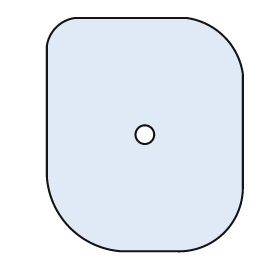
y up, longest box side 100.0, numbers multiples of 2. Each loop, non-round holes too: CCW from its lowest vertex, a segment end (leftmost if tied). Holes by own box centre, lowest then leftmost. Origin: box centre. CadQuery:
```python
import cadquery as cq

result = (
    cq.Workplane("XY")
    .moveTo(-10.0, -50.0)
    .lineTo(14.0, -50.0)
    .threePointArc((34.0, -42.0), (42.0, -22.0))
    .lineTo(42.0, 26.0)
    .threePointArc((34.0, 42.0), (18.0, 50.0))
    .lineTo(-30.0, 50.0)
    .threePointArc((-38.0, 46.0), (-42.0, 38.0))
    .lineTo(-42.0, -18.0)
    .threePointArc((-32.0, -40.0), (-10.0, -50.0))
    .close()
    .moveTo(0.0, 0.0)
    .circle(4.0)
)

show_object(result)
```